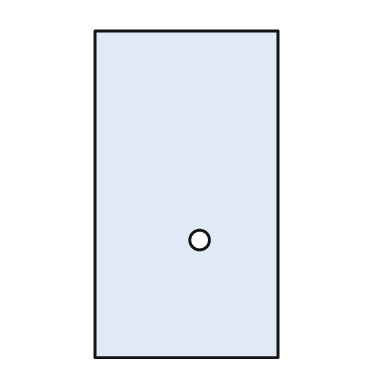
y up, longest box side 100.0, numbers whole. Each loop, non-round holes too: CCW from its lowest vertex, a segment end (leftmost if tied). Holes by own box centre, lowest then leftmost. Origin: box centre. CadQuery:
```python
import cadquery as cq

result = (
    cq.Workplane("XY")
    .moveTo(-28.0, -50.0)
    .lineTo(28.0, -50.0)
    .lineTo(28.0, 50.0)
    .lineTo(-28.0, 50.0)
    .close()
    .moveTo(4.0, -14.0)
    .circle(3.0)
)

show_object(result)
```